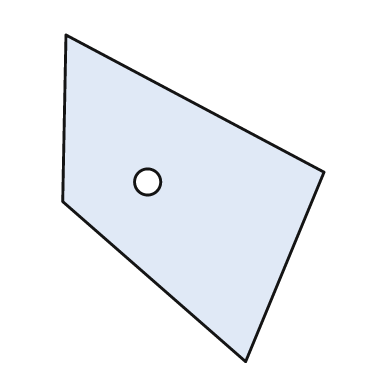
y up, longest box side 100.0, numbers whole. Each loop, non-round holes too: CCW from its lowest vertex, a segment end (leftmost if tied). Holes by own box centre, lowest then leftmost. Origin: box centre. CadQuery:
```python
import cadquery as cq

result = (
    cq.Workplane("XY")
    .moveTo(16.0, -50.0)
    .lineTo(40.0, 8.0)
    .lineTo(-39.0, 50.0)
    .lineTo(-40.0, -1.0)
    .close()
    .moveTo(-14.0, 5.0)
    .circle(4.0)
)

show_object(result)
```